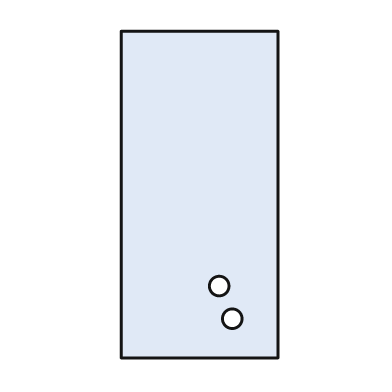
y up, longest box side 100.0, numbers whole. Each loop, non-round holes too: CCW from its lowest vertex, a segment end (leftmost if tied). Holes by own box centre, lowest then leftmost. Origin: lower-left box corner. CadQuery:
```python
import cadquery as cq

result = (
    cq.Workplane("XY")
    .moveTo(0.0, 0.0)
    .lineTo(48.0, 0.0)
    .lineTo(48.0, 100.0)
    .lineTo(0.0, 100.0)
    .close()
    .moveTo(34.0, 12.0)
    .circle(3.0)
    .moveTo(30.0, 22.0)
    .circle(3.0)
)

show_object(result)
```